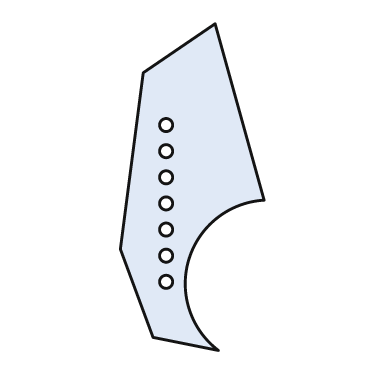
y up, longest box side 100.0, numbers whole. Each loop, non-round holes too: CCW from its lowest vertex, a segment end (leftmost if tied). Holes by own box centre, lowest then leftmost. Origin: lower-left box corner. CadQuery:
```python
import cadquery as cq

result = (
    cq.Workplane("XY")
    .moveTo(30.0, 0.0)
    .threePointArc((21.0, 28.0), (44.0, 46.0))
    .lineTo(29.0, 100.0)
    .lineTo(7.0, 85.0)
    .lineTo(0.0, 31.0)
    .lineTo(10.0, 4.0)
    .close()
    .moveTo(14.0, 21.0)
    .circle(2.0)
    .moveTo(14.0, 29.0)
    .circle(2.0)
    .moveTo(14.0, 37.0)
    .circle(2.0)
    .moveTo(14.0, 45.0)
    .circle(2.0)
    .moveTo(14.0, 53.0)
    .circle(2.0)
    .moveTo(14.0, 61.0)
    .circle(2.0)
    .moveTo(14.0, 69.0)
    .circle(2.0)
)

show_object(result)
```